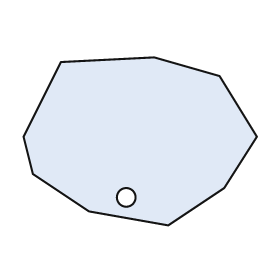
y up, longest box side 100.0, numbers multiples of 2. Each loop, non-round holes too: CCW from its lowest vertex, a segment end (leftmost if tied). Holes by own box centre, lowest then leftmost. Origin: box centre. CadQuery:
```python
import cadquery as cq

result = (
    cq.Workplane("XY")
    .moveTo(12.0, -36.0)
    .lineTo(36.0, -20.0)
    .lineTo(50.0, 2.0)
    .lineTo(34.0, 28.0)
    .lineTo(6.0, 36.0)
    .lineTo(-34.0, 34.0)
    .lineTo(-50.0, 2.0)
    .lineTo(-46.0, -14.0)
    .lineTo(-22.0, -30.0)
    .close()
    .moveTo(-6.0, -24.0)
    .circle(4.0)
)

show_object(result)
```